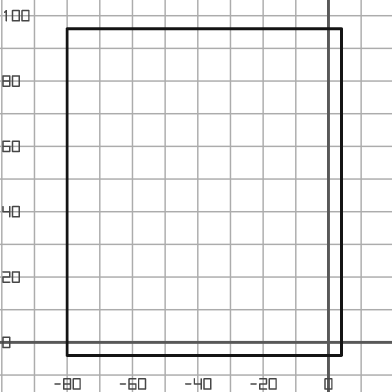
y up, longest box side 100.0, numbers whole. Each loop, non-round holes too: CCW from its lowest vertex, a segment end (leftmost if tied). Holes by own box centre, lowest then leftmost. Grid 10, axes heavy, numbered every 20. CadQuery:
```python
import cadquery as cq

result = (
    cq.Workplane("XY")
    .moveTo(-80.0, -4.0)
    .lineTo(4.0, -4.0)
    .lineTo(4.0, 96.0)
    .lineTo(-80.0, 96.0)
    .close()
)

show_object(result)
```